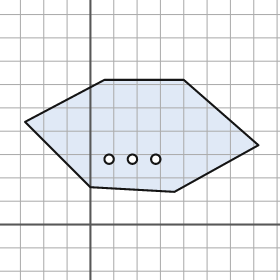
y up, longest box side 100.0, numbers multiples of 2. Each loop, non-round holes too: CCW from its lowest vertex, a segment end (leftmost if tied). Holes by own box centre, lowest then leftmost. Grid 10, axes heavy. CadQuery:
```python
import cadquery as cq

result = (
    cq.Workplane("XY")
    .moveTo(36.0, 14.0)
    .lineTo(72.0, 34.0)
    .lineTo(40.0, 62.0)
    .lineTo(6.0, 62.0)
    .lineTo(-28.0, 44.0)
    .lineTo(0.0, 16.0)
    .close()
    .moveTo(8.0, 28.0)
    .circle(2.0)
    .moveTo(18.0, 28.0)
    .circle(2.0)
    .moveTo(28.0, 28.0)
    .circle(2.0)
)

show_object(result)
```